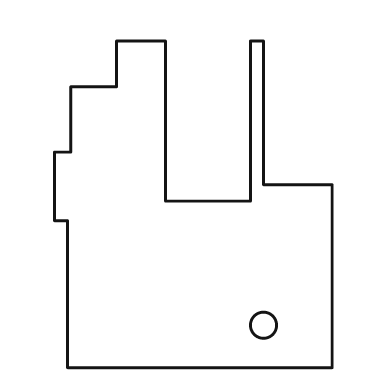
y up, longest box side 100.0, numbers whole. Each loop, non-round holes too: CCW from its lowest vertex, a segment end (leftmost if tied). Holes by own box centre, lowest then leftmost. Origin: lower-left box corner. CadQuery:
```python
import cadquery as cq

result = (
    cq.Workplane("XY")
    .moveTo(4.0, 0.0)
    .lineTo(85.0, 0.0)
    .lineTo(85.0, 56.0)
    .lineTo(64.0, 56.0)
    .lineTo(64.0, 100.0)
    .lineTo(60.0, 100.0)
    .lineTo(60.0, 51.0)
    .lineTo(34.0, 51.0)
    .lineTo(34.0, 100.0)
    .lineTo(19.0, 100.0)
    .lineTo(19.0, 86.0)
    .lineTo(5.0, 86.0)
    .lineTo(5.0, 66.0)
    .lineTo(0.0, 66.0)
    .lineTo(0.0, 45.0)
    .lineTo(4.0, 45.0)
    .close()
    .moveTo(64.0, 13.0)
    .circle(4.0)
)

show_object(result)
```